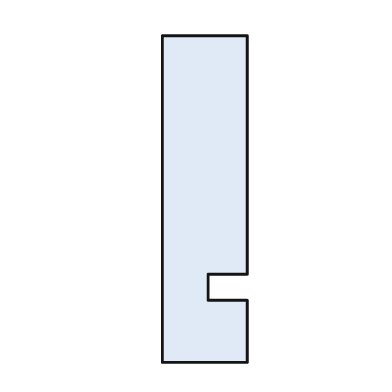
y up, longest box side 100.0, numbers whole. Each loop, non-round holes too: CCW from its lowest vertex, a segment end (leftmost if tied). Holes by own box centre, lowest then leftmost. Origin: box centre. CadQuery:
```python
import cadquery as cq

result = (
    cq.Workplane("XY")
    .moveTo(-13.0, -50.0)
    .lineTo(13.0, -50.0)
    .lineTo(13.0, -31.0)
    .lineTo(1.0, -31.0)
    .lineTo(1.0, -23.0)
    .lineTo(13.0, -23.0)
    .lineTo(13.0, 50.0)
    .lineTo(-13.0, 50.0)
    .close()
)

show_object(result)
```